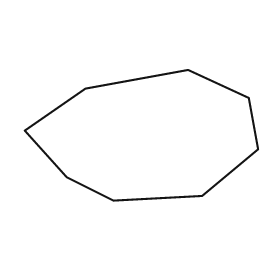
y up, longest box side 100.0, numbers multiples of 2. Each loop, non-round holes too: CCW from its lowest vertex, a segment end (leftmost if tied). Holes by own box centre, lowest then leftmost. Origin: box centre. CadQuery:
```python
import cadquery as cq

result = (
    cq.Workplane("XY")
    .moveTo(-12.0, -28.0)
    .lineTo(26.0, -26.0)
    .lineTo(50.0, -6.0)
    .lineTo(46.0, 16.0)
    .lineTo(20.0, 28.0)
    .lineTo(-24.0, 20.0)
    .lineTo(-50.0, 2.0)
    .lineTo(-32.0, -18.0)
    .close()
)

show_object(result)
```